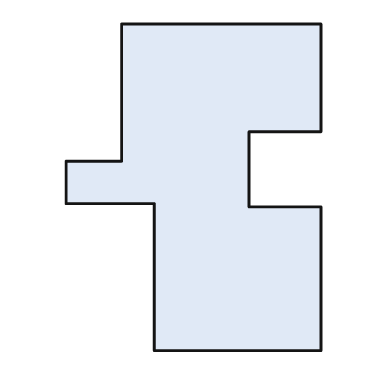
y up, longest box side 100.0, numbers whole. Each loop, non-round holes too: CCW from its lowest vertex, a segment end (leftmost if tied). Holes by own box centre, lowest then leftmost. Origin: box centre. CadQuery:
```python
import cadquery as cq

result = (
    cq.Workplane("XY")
    .moveTo(-12.0, -50.0)
    .lineTo(39.0, -50.0)
    .lineTo(39.0, -6.0)
    .lineTo(17.0, -6.0)
    .lineTo(17.0, 17.0)
    .lineTo(39.0, 17.0)
    .lineTo(39.0, 50.0)
    .lineTo(-22.0, 50.0)
    .lineTo(-22.0, 8.0)
    .lineTo(-39.0, 8.0)
    .lineTo(-39.0, -5.0)
    .lineTo(-12.0, -5.0)
    .close()
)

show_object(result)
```